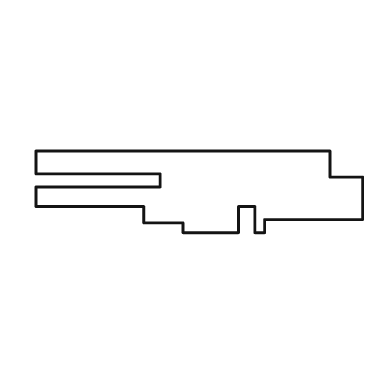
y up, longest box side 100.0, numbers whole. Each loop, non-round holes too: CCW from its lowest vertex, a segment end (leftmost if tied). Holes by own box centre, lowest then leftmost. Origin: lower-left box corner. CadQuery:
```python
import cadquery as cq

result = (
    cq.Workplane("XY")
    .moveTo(45.0, 0.0)
    .lineTo(62.0, 0.0)
    .lineTo(62.0, 8.0)
    .lineTo(67.0, 8.0)
    .lineTo(67.0, 0.0)
    .lineTo(70.0, 0.0)
    .lineTo(70.0, 4.0)
    .lineTo(100.0, 4.0)
    .lineTo(100.0, 17.0)
    .lineTo(90.0, 17.0)
    .lineTo(90.0, 25.0)
    .lineTo(0.0, 25.0)
    .lineTo(0.0, 18.0)
    .lineTo(38.0, 18.0)
    .lineTo(38.0, 14.0)
    .lineTo(0.0, 14.0)
    .lineTo(0.0, 8.0)
    .lineTo(33.0, 8.0)
    .lineTo(33.0, 3.0)
    .lineTo(45.0, 3.0)
    .close()
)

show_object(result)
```